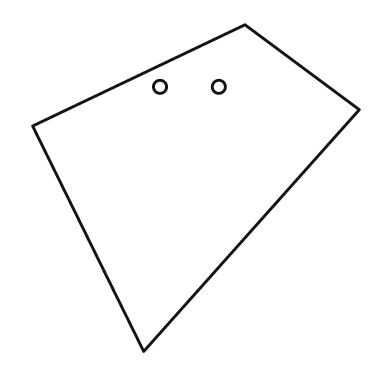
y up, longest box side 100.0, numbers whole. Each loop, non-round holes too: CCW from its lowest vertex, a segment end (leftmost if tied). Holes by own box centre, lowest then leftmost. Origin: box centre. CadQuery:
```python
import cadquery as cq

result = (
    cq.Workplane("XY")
    .moveTo(-16.0, -50.0)
    .lineTo(50.0, 24.0)
    .lineTo(15.0, 50.0)
    .lineTo(-50.0, 19.0)
    .close()
    .moveTo(-11.0, 31.0)
    .circle(2.0)
    .moveTo(7.0, 31.0)
    .circle(2.0)
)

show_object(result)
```